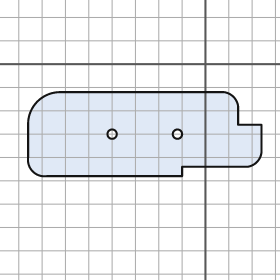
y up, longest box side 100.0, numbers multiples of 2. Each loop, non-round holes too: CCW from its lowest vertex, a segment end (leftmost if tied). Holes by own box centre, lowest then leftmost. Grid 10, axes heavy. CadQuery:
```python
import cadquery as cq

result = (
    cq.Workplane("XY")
    .moveTo(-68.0, -48.0)
    .lineTo(-10.0, -48.0)
    .lineTo(-10.0, -44.0)
    .lineTo(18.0, -44.0)
    .threePointArc((22.0, -42.0), (24.0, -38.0))
    .lineTo(24.0, -26.0)
    .lineTo(14.0, -26.0)
    .lineTo(14.0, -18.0)
    .threePointArc((12.0, -14.0), (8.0, -12.0))
    .lineTo(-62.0, -12.0)
    .threePointArc((-72.0, -16.0), (-76.0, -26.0))
    .lineTo(-76.0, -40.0)
    .threePointArc((-74.0, -46.0), (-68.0, -48.0))
    .close()
    .moveTo(-40.0, -30.0)
    .circle(2.0)
    .moveTo(-12.0, -30.0)
    .circle(2.0)
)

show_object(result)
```